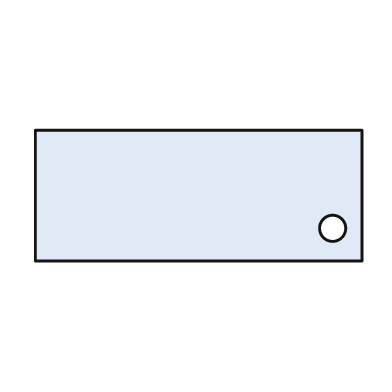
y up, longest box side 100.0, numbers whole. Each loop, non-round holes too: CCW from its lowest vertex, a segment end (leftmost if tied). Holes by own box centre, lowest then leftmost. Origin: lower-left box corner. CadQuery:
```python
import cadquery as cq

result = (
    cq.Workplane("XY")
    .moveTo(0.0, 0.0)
    .lineTo(100.0, 0.0)
    .lineTo(100.0, 40.0)
    .lineTo(0.0, 40.0)
    .close()
    .moveTo(91.0, 10.0)
    .circle(4.0)
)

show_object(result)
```